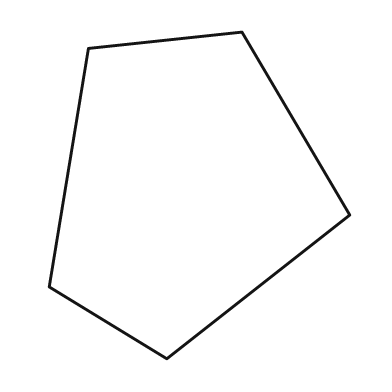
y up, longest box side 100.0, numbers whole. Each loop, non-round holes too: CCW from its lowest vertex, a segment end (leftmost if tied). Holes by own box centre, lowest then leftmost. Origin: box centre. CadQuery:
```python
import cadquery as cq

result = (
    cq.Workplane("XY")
    .moveTo(-10.0, -50.0)
    .lineTo(46.0, -6.0)
    .lineTo(13.0, 50.0)
    .lineTo(-34.0, 45.0)
    .lineTo(-46.0, -28.0)
    .close()
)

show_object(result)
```